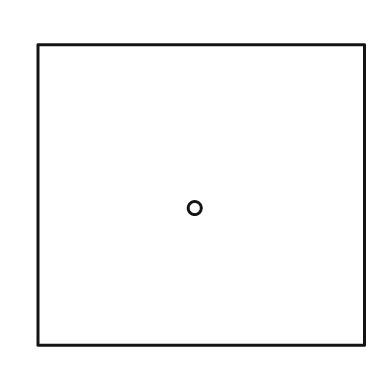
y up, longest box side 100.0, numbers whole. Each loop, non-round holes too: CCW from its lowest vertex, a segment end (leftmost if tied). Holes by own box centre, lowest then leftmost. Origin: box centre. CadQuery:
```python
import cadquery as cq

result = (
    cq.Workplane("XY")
    .moveTo(-50.0, -46.0)
    .lineTo(50.0, -46.0)
    .lineTo(50.0, 46.0)
    .lineTo(-50.0, 46.0)
    .close()
    .moveTo(-2.0, -4.0)
    .circle(2.0)
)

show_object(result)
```